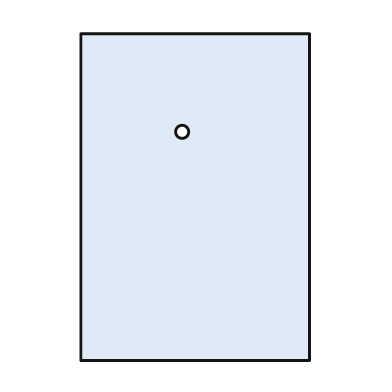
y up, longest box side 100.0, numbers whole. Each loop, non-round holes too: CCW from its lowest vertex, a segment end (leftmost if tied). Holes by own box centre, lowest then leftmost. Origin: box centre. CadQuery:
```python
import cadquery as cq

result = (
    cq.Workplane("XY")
    .moveTo(-35.0, -50.0)
    .lineTo(35.0, -50.0)
    .lineTo(35.0, 50.0)
    .lineTo(-35.0, 50.0)
    .close()
    .moveTo(-4.0, 20.0)
    .circle(2.0)
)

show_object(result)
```